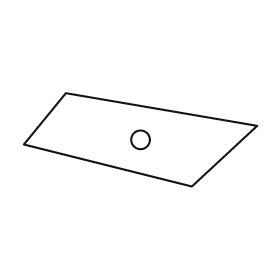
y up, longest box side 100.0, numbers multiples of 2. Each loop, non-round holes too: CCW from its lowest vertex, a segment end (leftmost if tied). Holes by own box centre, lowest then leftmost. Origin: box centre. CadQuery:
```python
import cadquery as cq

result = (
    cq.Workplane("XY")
    .moveTo(22.0, -20.0)
    .lineTo(50.0, 6.0)
    .lineTo(-32.0, 20.0)
    .lineTo(-50.0, -2.0)
    .close()
    .moveTo(0.0, 0.0)
    .circle(4.0)
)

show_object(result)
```